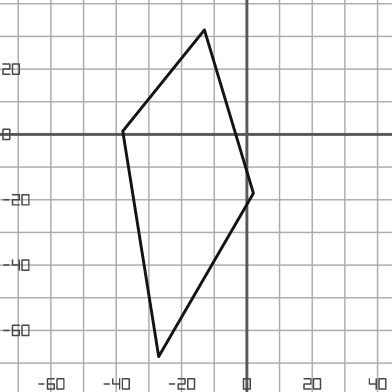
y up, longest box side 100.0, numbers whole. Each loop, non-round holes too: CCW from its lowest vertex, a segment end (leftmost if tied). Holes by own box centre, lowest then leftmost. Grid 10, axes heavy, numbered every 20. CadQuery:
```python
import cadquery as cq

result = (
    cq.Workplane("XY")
    .moveTo(-27.0, -68.0)
    .lineTo(2.0, -18.0)
    .lineTo(-13.0, 32.0)
    .lineTo(-38.0, 1.0)
    .close()
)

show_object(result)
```